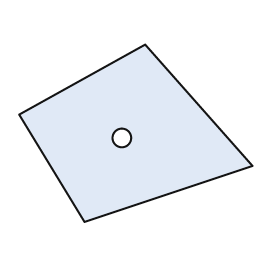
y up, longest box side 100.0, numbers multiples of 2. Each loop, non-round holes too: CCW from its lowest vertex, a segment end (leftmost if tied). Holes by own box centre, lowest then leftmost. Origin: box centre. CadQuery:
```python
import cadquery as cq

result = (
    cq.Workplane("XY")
    .moveTo(-22.0, -38.0)
    .lineTo(50.0, -14.0)
    .lineTo(4.0, 38.0)
    .lineTo(-50.0, 8.0)
    .close()
    .moveTo(-6.0, -2.0)
    .circle(4.0)
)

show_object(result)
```